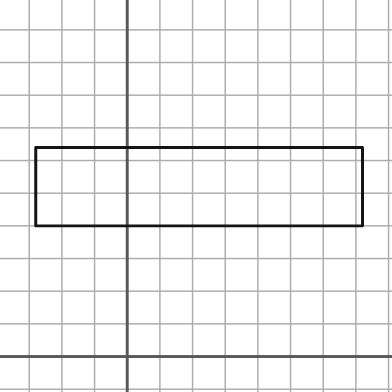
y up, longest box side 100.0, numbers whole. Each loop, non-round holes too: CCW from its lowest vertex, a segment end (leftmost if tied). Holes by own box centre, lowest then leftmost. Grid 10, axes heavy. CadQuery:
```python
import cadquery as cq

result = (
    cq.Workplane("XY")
    .moveTo(-28.0, 40.0)
    .lineTo(72.0, 40.0)
    .lineTo(72.0, 64.0)
    .lineTo(-28.0, 64.0)
    .close()
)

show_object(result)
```